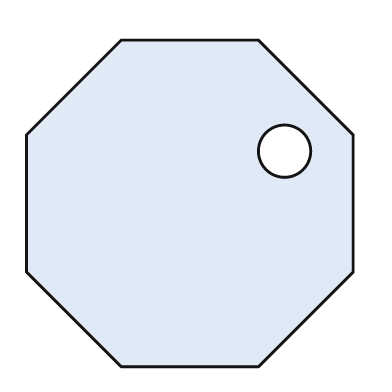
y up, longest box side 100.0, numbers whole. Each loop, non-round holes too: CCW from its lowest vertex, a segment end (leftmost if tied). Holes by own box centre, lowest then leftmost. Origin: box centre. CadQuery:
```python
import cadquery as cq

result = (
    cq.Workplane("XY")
    .moveTo(-21.0, -50.0)
    .lineTo(21.0, -50.0)
    .lineTo(50.0, -21.0)
    .lineTo(50.0, 21.0)
    .lineTo(21.0, 50.0)
    .lineTo(-21.0, 50.0)
    .lineTo(-50.0, 21.0)
    .lineTo(-50.0, -21.0)
    .close()
    .moveTo(29.0, 16.0)
    .circle(8.0)
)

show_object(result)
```